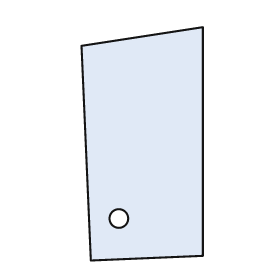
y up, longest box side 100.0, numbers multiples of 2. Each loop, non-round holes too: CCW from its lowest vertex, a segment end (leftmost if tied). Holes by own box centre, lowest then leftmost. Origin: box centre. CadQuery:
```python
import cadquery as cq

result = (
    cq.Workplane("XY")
    .moveTo(-22.0, -50.0)
    .lineTo(26.0, -48.0)
    .lineTo(26.0, 50.0)
    .lineTo(-26.0, 42.0)
    .close()
    .moveTo(-10.0, -32.0)
    .circle(4.0)
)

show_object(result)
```